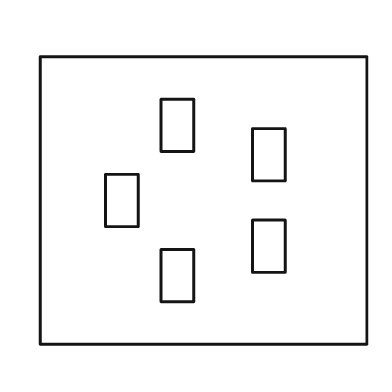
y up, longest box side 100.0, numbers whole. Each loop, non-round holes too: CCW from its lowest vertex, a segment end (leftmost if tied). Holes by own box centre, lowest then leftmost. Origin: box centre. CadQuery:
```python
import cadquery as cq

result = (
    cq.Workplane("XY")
    .moveTo(-50.0, -44.0)
    .lineTo(50.0, -44.0)
    .lineTo(50.0, 44.0)
    .lineTo(-50.0, 44.0)
    .close()
    .moveTo(-13.0, -31.0)
    .lineTo(-3.0, -31.0)
    .lineTo(-3.0, -15.0)
    .lineTo(-13.0, -15.0)
    .close()
    .moveTo(15.0, -22.0)
    .lineTo(25.0, -22.0)
    .lineTo(25.0, -6.0)
    .lineTo(15.0, -6.0)
    .close()
    .moveTo(-30.0, -8.0)
    .lineTo(-20.0, -8.0)
    .lineTo(-20.0, 8.0)
    .lineTo(-30.0, 8.0)
    .close()
    .moveTo(15.0, 6.0)
    .lineTo(25.0, 6.0)
    .lineTo(25.0, 22.0)
    .lineTo(15.0, 22.0)
    .close()
    .moveTo(-13.0, 15.0)
    .lineTo(-3.0, 15.0)
    .lineTo(-3.0, 31.0)
    .lineTo(-13.0, 31.0)
    .close()
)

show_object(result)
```